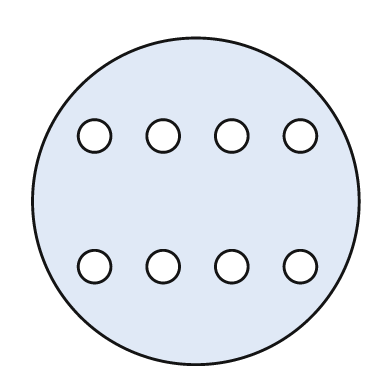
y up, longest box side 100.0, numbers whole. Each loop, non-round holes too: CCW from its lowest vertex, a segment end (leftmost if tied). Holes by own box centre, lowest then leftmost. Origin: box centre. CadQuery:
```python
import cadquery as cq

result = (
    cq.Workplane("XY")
    .moveTo(0.0, 0.0)
    .circle(50.0)
    .moveTo(-31.0, -20.0)
    .circle(5.0)
    .moveTo(-10.0, -20.0)
    .circle(5.0)
    .moveTo(11.0, -20.0)
    .circle(5.0)
    .moveTo(32.0, -20.0)
    .circle(5.0)
    .moveTo(-31.0, 20.0)
    .circle(5.0)
    .moveTo(-10.0, 20.0)
    .circle(5.0)
    .moveTo(11.0, 20.0)
    .circle(5.0)
    .moveTo(32.0, 20.0)
    .circle(5.0)
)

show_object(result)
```